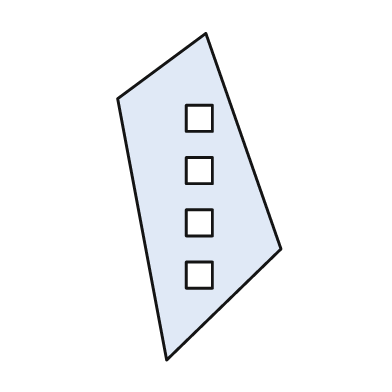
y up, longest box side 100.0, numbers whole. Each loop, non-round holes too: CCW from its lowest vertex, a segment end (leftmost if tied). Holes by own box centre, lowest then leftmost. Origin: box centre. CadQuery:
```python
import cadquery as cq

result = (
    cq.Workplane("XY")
    .moveTo(-10.0, -50.0)
    .lineTo(25.0, -16.0)
    .lineTo(2.0, 50.0)
    .lineTo(-25.0, 30.0)
    .close()
    .moveTo(-4.0, -28.0)
    .lineTo(4.0, -28.0)
    .lineTo(4.0, -20.0)
    .lineTo(-4.0, -20.0)
    .close()
    .moveTo(-4.0, -12.0)
    .lineTo(4.0, -12.0)
    .lineTo(4.0, -4.0)
    .lineTo(-4.0, -4.0)
    .close()
    .moveTo(-4.0, 4.0)
    .lineTo(4.0, 4.0)
    .lineTo(4.0, 12.0)
    .lineTo(-4.0, 12.0)
    .close()
    .moveTo(-4.0, 20.0)
    .lineTo(4.0, 20.0)
    .lineTo(4.0, 28.0)
    .lineTo(-4.0, 28.0)
    .close()
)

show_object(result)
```